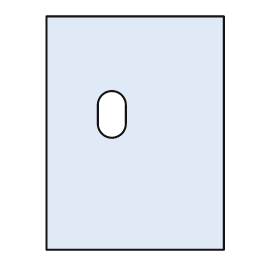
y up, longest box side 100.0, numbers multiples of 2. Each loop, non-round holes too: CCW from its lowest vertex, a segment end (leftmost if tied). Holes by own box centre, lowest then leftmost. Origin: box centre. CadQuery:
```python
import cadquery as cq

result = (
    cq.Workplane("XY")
    .moveTo(-38.0, -50.0)
    .lineTo(38.0, -50.0)
    .lineTo(38.0, 50.0)
    .lineTo(-38.0, 50.0)
    .close()
    .moveTo(-16.0, 4.0)
    .threePointArc((-10.0, -2.0), (-4.0, 4.0))
    .lineTo(-4.0, 12.0)
    .threePointArc((-10.0, 18.0), (-16.0, 12.0))
    .close()
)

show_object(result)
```